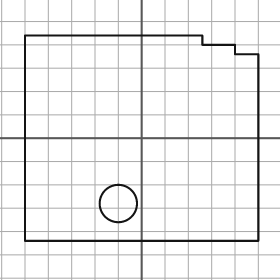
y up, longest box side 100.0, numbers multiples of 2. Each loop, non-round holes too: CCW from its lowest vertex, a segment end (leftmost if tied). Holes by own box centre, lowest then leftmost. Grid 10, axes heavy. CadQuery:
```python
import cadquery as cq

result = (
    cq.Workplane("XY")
    .moveTo(-50.0, -44.0)
    .lineTo(50.0, -44.0)
    .lineTo(50.0, 36.0)
    .lineTo(40.0, 36.0)
    .lineTo(40.0, 40.0)
    .lineTo(26.0, 40.0)
    .lineTo(26.0, 44.0)
    .lineTo(-50.0, 44.0)
    .close()
    .moveTo(-10.0, -28.0)
    .circle(8.0)
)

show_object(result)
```